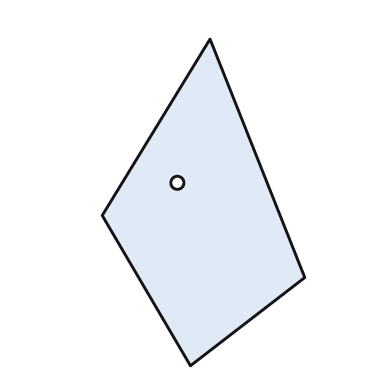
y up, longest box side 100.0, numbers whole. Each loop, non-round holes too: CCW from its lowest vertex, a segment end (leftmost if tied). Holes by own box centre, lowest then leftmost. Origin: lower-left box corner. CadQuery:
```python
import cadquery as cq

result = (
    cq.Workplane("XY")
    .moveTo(27.0, 0.0)
    .lineTo(62.0, 27.0)
    .lineTo(33.0, 100.0)
    .lineTo(0.0, 46.0)
    .close()
    .moveTo(23.0, 56.0)
    .circle(2.0)
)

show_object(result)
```